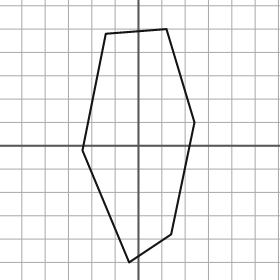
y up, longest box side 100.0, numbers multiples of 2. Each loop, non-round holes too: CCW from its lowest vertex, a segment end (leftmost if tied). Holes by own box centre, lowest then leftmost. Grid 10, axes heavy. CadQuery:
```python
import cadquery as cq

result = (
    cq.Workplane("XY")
    .moveTo(-4.0, -50.0)
    .lineTo(14.0, -38.0)
    .lineTo(24.0, 10.0)
    .lineTo(12.0, 50.0)
    .lineTo(-14.0, 48.0)
    .lineTo(-24.0, -2.0)
    .close()
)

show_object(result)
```